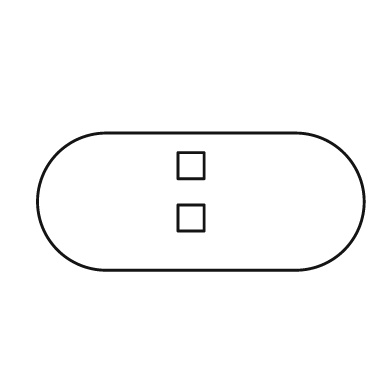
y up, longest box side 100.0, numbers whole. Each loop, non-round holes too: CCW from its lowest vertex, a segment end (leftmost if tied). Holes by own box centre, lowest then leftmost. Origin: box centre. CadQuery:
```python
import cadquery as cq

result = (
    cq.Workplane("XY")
    .moveTo(-29.0, -21.0)
    .lineTo(29.0, -21.0)
    .threePointArc((50.0, 0.0), (29.0, 21.0))
    .lineTo(-29.0, 21.0)
    .threePointArc((-50.0, 0.0), (-29.0, -21.0))
    .close()
    .moveTo(-7.0, -9.0)
    .lineTo(1.0, -9.0)
    .lineTo(1.0, -1.0)
    .lineTo(-7.0, -1.0)
    .close()
    .moveTo(-7.0, 7.0)
    .lineTo(1.0, 7.0)
    .lineTo(1.0, 15.0)
    .lineTo(-7.0, 15.0)
    .close()
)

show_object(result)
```